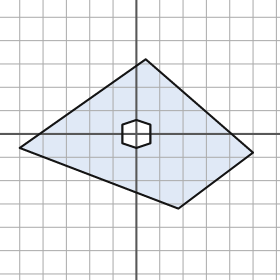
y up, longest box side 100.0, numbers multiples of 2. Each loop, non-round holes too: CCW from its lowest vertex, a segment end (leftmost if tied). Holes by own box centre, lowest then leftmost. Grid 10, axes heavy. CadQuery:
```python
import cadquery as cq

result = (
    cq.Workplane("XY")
    .moveTo(18.0, -32.0)
    .lineTo(50.0, -8.0)
    .lineTo(4.0, 32.0)
    .lineTo(-50.0, -6.0)
    .close()
    .moveTo(0.0, -6.0)
    .lineTo(6.0, -4.0)
    .lineTo(6.0, 4.0)
    .lineTo(0.0, 6.0)
    .lineTo(-6.0, 4.0)
    .lineTo(-6.0, -4.0)
    .close()
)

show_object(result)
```